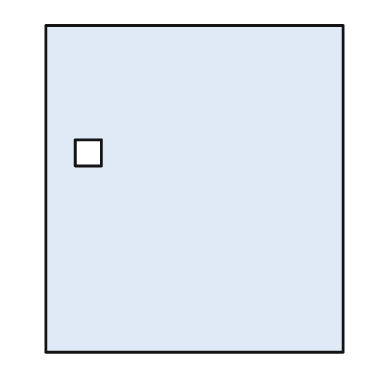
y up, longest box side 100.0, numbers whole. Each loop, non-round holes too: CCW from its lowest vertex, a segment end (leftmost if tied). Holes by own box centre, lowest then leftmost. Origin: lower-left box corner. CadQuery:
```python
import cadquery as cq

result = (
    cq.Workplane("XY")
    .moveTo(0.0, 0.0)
    .lineTo(91.0, 0.0)
    .lineTo(91.0, 100.0)
    .lineTo(0.0, 100.0)
    .close()
    .moveTo(9.0, 57.0)
    .lineTo(17.0, 57.0)
    .lineTo(17.0, 65.0)
    .lineTo(9.0, 65.0)
    .close()
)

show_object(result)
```